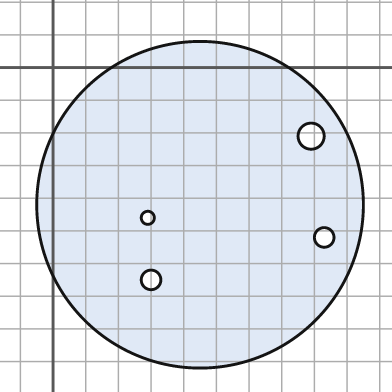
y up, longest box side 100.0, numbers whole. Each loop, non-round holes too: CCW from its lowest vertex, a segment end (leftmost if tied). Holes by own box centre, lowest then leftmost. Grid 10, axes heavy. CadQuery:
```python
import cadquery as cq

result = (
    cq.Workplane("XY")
    .moveTo(45.0, -42.0)
    .circle(50.0)
    .moveTo(30.0, -65.0)
    .circle(3.0)
    .moveTo(83.0, -52.0)
    .circle(3.0)
    .moveTo(29.0, -46.0)
    .circle(2.0)
    .moveTo(79.0, -21.0)
    .circle(4.0)
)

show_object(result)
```